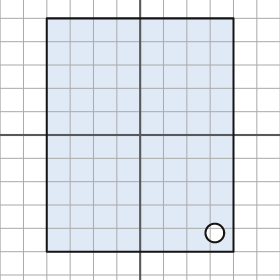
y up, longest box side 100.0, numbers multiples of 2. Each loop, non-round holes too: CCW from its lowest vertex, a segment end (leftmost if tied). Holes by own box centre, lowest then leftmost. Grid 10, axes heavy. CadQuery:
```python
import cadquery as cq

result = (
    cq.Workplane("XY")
    .moveTo(-40.0, -50.0)
    .lineTo(40.0, -50.0)
    .lineTo(40.0, 50.0)
    .lineTo(-40.0, 50.0)
    .close()
    .moveTo(32.0, -42.0)
    .circle(4.0)
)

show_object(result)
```